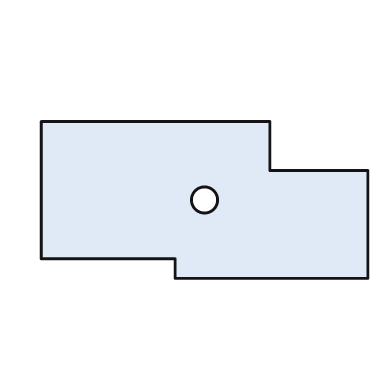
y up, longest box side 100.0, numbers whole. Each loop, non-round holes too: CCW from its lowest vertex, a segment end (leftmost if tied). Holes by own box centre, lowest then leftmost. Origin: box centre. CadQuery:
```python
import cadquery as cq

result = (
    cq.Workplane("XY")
    .moveTo(-9.0, -24.0)
    .lineTo(50.0, -24.0)
    .lineTo(50.0, 9.0)
    .lineTo(20.0, 9.0)
    .lineTo(20.0, 24.0)
    .lineTo(-50.0, 24.0)
    .lineTo(-50.0, -18.0)
    .lineTo(-9.0, -18.0)
    .close()
    .moveTo(0.0, 0.0)
    .circle(4.0)
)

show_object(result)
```